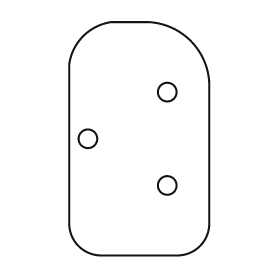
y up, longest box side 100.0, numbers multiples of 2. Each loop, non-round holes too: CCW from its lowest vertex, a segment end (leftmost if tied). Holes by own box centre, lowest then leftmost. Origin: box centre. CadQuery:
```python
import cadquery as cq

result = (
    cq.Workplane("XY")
    .moveTo(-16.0, -50.0)
    .lineTo(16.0, -50.0)
    .threePointArc((26.0, -46.0), (30.0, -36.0))
    .lineTo(30.0, 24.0)
    .threePointArc((22.0, 42.0), (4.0, 50.0))
    .lineTo(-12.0, 50.0)
    .threePointArc((-24.0, 44.0), (-30.0, 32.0))
    .lineTo(-30.0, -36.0)
    .threePointArc((-26.0, -46.0), (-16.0, -50.0))
    .close()
    .moveTo(12.0, -20.0)
    .circle(4.0)
    .moveTo(-22.0, 0.0)
    .circle(4.0)
    .moveTo(12.0, 20.0)
    .circle(4.0)
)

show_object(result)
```